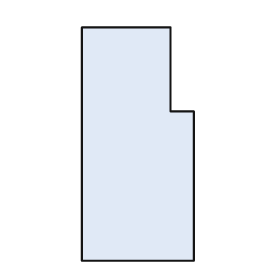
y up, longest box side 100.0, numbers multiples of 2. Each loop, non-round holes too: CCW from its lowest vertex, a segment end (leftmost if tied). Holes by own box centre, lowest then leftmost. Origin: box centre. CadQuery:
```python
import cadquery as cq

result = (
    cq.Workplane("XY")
    .moveTo(-24.0, -50.0)
    .lineTo(24.0, -50.0)
    .lineTo(24.0, 14.0)
    .lineTo(14.0, 14.0)
    .lineTo(14.0, 50.0)
    .lineTo(-24.0, 50.0)
    .close()
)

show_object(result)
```